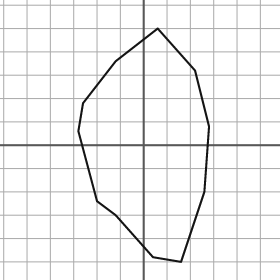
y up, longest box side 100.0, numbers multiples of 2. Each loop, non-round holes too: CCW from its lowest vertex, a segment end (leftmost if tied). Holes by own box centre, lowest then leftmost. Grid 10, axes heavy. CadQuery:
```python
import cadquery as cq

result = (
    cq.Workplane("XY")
    .moveTo(16.0, -50.0)
    .lineTo(26.0, -20.0)
    .lineTo(28.0, 8.0)
    .lineTo(22.0, 32.0)
    .lineTo(6.0, 50.0)
    .lineTo(-12.0, 36.0)
    .lineTo(-26.0, 18.0)
    .lineTo(-28.0, 6.0)
    .lineTo(-20.0, -24.0)
    .lineTo(-12.0, -30.0)
    .lineTo(4.0, -48.0)
    .close()
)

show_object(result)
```